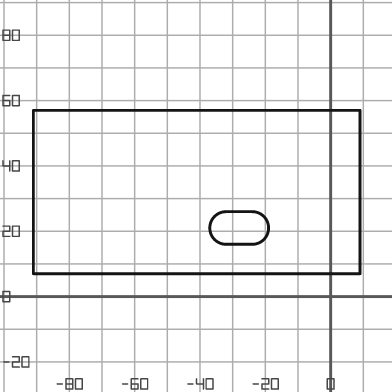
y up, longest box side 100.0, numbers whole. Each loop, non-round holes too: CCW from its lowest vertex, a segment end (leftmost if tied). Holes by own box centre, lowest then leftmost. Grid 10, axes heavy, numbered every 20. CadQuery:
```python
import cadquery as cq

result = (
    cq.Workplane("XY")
    .moveTo(-91.0, 7.0)
    .lineTo(9.0, 7.0)
    .lineTo(9.0, 57.0)
    .lineTo(-91.0, 57.0)
    .close()
    .moveTo(-32.0, 16.0)
    .lineTo(-24.0, 16.0)
    .threePointArc((-19.0, 21.0), (-24.0, 26.0))
    .lineTo(-32.0, 26.0)
    .threePointArc((-37.0, 21.0), (-32.0, 16.0))
    .close()
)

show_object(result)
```